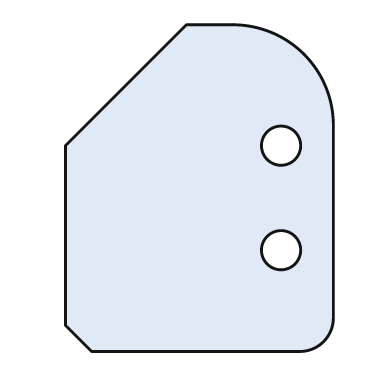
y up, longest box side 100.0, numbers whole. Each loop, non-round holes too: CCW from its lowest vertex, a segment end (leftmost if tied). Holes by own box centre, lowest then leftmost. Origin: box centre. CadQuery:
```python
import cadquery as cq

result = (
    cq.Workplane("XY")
    .moveTo(-33.0, -50.0)
    .lineTo(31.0, -50.0)
    .threePointArc((38.0, -47.0), (41.0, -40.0))
    .lineTo(41.0, 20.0)
    .threePointArc((32.0, 41.0), (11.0, 50.0))
    .lineTo(-4.0, 50.0)
    .lineTo(-41.0, 13.0)
    .lineTo(-41.0, -42.0)
    .close()
    .moveTo(25.0, -19.0)
    .circle(6.0)
    .moveTo(25.0, 13.0)
    .circle(6.0)
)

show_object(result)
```